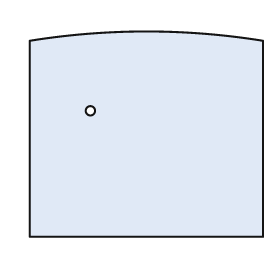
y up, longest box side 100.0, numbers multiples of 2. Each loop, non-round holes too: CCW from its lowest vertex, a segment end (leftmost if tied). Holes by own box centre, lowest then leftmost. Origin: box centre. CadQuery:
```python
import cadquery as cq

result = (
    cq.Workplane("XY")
    .moveTo(-50.0, -44.0)
    .lineTo(50.0, -44.0)
    .lineTo(50.0, 40.0)
    .threePointArc((0.0, 44.0), (-50.0, 40.0))
    .close()
    .moveTo(-24.0, 10.0)
    .circle(2.0)
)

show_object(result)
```